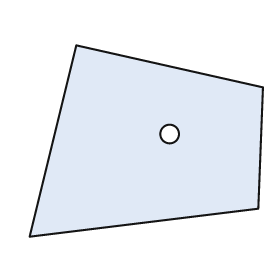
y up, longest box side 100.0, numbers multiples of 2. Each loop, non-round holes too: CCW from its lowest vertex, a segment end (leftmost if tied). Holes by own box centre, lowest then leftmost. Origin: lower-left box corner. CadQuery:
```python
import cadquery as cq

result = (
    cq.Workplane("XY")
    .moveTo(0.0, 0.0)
    .lineTo(98.0, 12.0)
    .lineTo(100.0, 64.0)
    .lineTo(20.0, 82.0)
    .close()
    .moveTo(60.0, 44.0)
    .circle(4.0)
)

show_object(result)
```